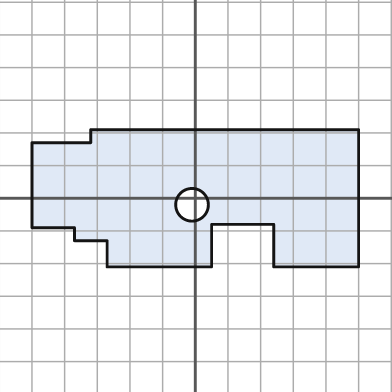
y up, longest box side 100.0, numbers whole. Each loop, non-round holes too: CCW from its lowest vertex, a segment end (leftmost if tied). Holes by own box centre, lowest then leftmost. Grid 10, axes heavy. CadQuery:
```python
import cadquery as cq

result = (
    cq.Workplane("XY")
    .moveTo(-27.0, -21.0)
    .lineTo(5.0, -21.0)
    .lineTo(5.0, -8.0)
    .lineTo(24.0, -8.0)
    .lineTo(24.0, -21.0)
    .lineTo(50.0, -21.0)
    .lineTo(50.0, 21.0)
    .lineTo(-32.0, 21.0)
    .lineTo(-32.0, 17.0)
    .lineTo(-50.0, 17.0)
    .lineTo(-50.0, -9.0)
    .lineTo(-37.0, -9.0)
    .lineTo(-37.0, -13.0)
    .lineTo(-27.0, -13.0)
    .close()
    .moveTo(-1.0, -2.0)
    .circle(5.0)
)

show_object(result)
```